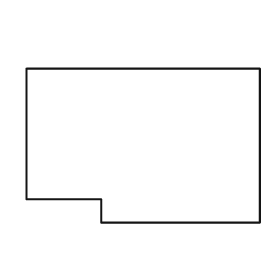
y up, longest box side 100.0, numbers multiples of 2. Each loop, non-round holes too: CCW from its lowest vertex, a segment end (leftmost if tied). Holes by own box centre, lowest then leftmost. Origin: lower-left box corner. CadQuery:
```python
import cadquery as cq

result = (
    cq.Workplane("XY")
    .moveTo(32.0, 0.0)
    .lineTo(100.0, 0.0)
    .lineTo(100.0, 66.0)
    .lineTo(0.0, 66.0)
    .lineTo(0.0, 10.0)
    .lineTo(32.0, 10.0)
    .close()
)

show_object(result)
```